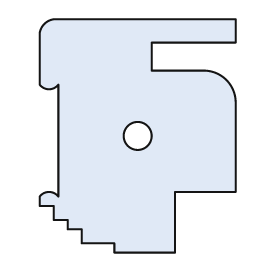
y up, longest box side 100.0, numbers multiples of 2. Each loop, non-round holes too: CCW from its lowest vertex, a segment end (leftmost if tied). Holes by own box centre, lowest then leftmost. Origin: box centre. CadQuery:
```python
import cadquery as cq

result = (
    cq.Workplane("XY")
    .moveTo(-10.0, -50.0)
    .lineTo(16.0, -50.0)
    .lineTo(16.0, -24.0)
    .lineTo(42.0, -24.0)
    .lineTo(42.0, 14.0)
    .threePointArc((38.0, 24.0), (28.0, 28.0))
    .lineTo(6.0, 28.0)
    .lineTo(6.0, 40.0)
    .lineTo(42.0, 40.0)
    .lineTo(42.0, 50.0)
    .lineTo(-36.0, 50.0)
    .threePointArc((-40.0, 48.0), (-42.0, 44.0))
    .lineTo(-42.0, 22.0)
    .threePointArc((-38.0, 20.0), (-34.0, 22.0))
    .lineTo(-34.0, -26.0)
    .threePointArc((-38.0, -24.0), (-42.0, -26.0))
    .lineTo(-42.0, -30.0)
    .lineTo(-36.0, -30.0)
    .lineTo(-36.0, -36.0)
    .lineTo(-30.0, -36.0)
    .lineTo(-30.0, -40.0)
    .lineTo(-24.0, -40.0)
    .lineTo(-24.0, -46.0)
    .lineTo(-10.0, -46.0)
    .close()
    .moveTo(0.0, 0.0)
    .circle(6.0)
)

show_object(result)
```